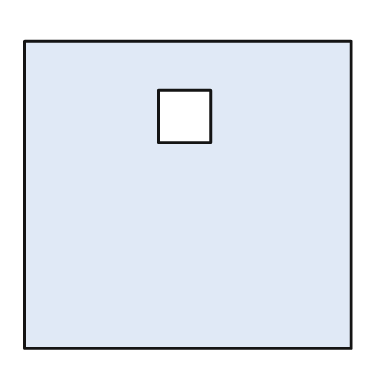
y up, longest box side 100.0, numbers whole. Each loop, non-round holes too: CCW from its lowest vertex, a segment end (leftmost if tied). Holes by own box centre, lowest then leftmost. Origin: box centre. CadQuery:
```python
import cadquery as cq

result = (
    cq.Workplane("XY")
    .moveTo(-50.0, -47.0)
    .lineTo(50.0, -47.0)
    .lineTo(50.0, 47.0)
    .lineTo(-50.0, 47.0)
    .close()
    .moveTo(-9.0, 16.0)
    .lineTo(7.0, 16.0)
    .lineTo(7.0, 32.0)
    .lineTo(-9.0, 32.0)
    .close()
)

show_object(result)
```